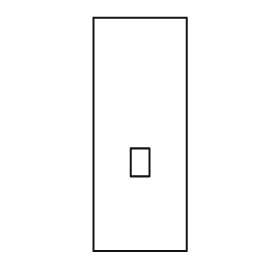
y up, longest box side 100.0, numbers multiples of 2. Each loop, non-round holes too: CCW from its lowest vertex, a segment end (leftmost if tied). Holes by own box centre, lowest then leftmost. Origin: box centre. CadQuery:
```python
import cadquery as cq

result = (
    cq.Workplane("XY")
    .moveTo(-20.0, -50.0)
    .lineTo(20.0, -50.0)
    .lineTo(20.0, 50.0)
    .lineTo(-20.0, 50.0)
    .close()
    .moveTo(-4.0, -18.0)
    .lineTo(4.0, -18.0)
    .lineTo(4.0, -6.0)
    .lineTo(-4.0, -6.0)
    .close()
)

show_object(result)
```